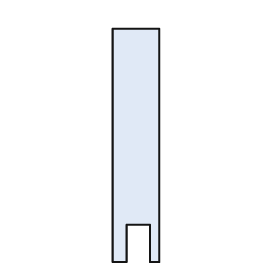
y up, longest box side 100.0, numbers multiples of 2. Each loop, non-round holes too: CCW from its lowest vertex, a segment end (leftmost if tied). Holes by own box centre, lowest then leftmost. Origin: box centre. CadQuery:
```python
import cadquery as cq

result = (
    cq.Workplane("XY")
    .moveTo(-10.0, -50.0)
    .lineTo(-4.0, -50.0)
    .lineTo(-4.0, -34.0)
    .lineTo(6.0, -34.0)
    .lineTo(6.0, -50.0)
    .lineTo(10.0, -50.0)
    .lineTo(10.0, 50.0)
    .lineTo(-10.0, 50.0)
    .close()
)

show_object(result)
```